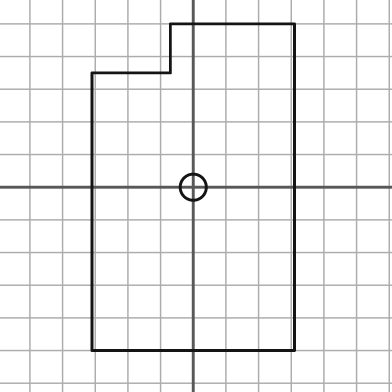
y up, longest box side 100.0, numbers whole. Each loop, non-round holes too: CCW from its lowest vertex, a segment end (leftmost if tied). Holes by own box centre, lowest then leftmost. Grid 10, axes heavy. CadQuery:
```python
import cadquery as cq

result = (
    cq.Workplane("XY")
    .moveTo(-31.0, -50.0)
    .lineTo(31.0, -50.0)
    .lineTo(31.0, 50.0)
    .lineTo(-7.0, 50.0)
    .lineTo(-7.0, 35.0)
    .lineTo(-31.0, 35.0)
    .close()
    .moveTo(0.0, 0.0)
    .circle(4.0)
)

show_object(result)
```